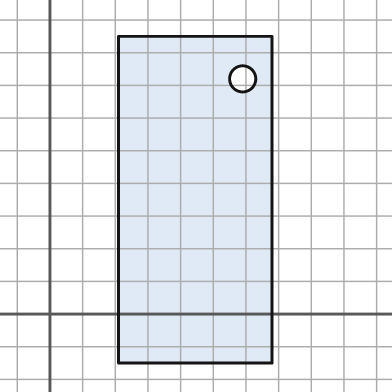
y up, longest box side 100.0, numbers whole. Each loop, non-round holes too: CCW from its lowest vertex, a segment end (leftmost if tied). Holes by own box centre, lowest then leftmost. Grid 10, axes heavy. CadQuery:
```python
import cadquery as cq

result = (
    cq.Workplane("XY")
    .moveTo(21.0, -15.0)
    .lineTo(68.0, -15.0)
    .lineTo(68.0, 85.0)
    .lineTo(21.0, 85.0)
    .close()
    .moveTo(59.0, 72.0)
    .circle(4.0)
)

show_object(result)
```